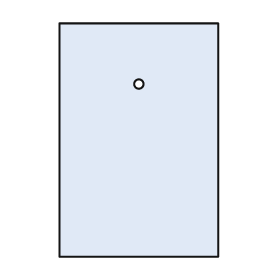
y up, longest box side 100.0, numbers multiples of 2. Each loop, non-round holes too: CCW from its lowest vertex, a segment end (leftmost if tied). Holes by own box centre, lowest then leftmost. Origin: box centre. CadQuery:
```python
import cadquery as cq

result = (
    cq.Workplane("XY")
    .moveTo(-34.0, -50.0)
    .lineTo(34.0, -50.0)
    .lineTo(34.0, 50.0)
    .lineTo(-34.0, 50.0)
    .close()
    .moveTo(0.0, 24.0)
    .circle(2.0)
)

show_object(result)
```